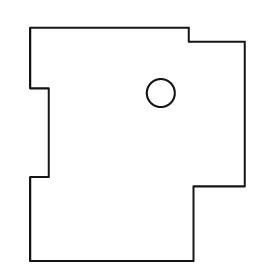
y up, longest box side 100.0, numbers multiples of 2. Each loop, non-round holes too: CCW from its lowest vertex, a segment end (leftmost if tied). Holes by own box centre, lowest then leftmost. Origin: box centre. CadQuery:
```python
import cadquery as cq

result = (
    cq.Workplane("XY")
    .moveTo(-46.0, -50.0)
    .lineTo(24.0, -50.0)
    .lineTo(24.0, -18.0)
    .lineTo(46.0, -18.0)
    .lineTo(46.0, 44.0)
    .lineTo(22.0, 44.0)
    .lineTo(22.0, 50.0)
    .lineTo(-46.0, 50.0)
    .lineTo(-46.0, 24.0)
    .lineTo(-38.0, 24.0)
    .lineTo(-38.0, -14.0)
    .lineTo(-46.0, -14.0)
    .close()
    .moveTo(10.0, 22.0)
    .circle(6.0)
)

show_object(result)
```